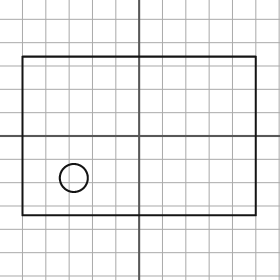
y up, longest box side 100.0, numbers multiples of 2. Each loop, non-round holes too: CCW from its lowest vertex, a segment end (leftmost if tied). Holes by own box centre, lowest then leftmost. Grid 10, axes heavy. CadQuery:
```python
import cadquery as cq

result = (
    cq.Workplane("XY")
    .moveTo(-50.0, -34.0)
    .lineTo(50.0, -34.0)
    .lineTo(50.0, 34.0)
    .lineTo(-50.0, 34.0)
    .close()
    .moveTo(-28.0, -18.0)
    .circle(6.0)
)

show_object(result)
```